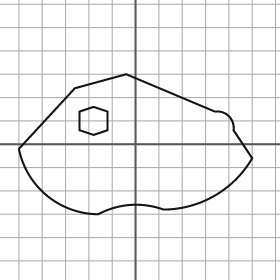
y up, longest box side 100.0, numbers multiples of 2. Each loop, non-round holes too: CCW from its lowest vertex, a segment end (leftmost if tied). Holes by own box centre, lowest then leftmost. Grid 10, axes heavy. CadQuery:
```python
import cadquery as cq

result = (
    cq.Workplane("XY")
    .moveTo(-16.0, -30.0)
    .threePointArc((-2.0, -26.0), (12.0, -28.0))
    .threePointArc((34.0, -22.0), (50.0, -6.0))
    .lineTo(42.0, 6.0)
    .threePointArc((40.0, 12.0), (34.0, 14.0))
    .lineTo(-4.0, 30.0)
    .lineTo(-26.0, 24.0)
    .lineTo(-50.0, -2.0)
    .threePointArc((-38.0, -22.0), (-16.0, -30.0))
    .close()
    .moveTo(-18.0, 4.0)
    .lineTo(-12.0, 6.0)
    .lineTo(-12.0, 14.0)
    .lineTo(-18.0, 16.0)
    .lineTo(-24.0, 14.0)
    .lineTo(-24.0, 6.0)
    .close()
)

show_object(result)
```